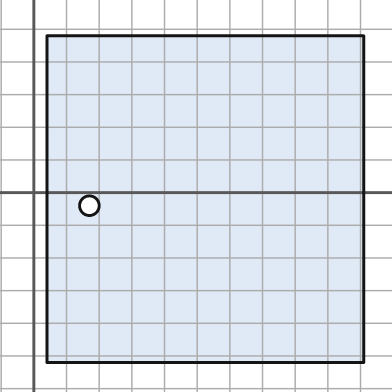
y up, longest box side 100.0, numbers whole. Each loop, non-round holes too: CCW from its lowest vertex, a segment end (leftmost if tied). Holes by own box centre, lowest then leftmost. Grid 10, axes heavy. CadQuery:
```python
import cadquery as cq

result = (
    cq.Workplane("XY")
    .moveTo(4.0, -52.0)
    .lineTo(101.0, -52.0)
    .lineTo(101.0, 48.0)
    .lineTo(4.0, 48.0)
    .close()
    .moveTo(17.0, -4.0)
    .circle(3.0)
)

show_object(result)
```